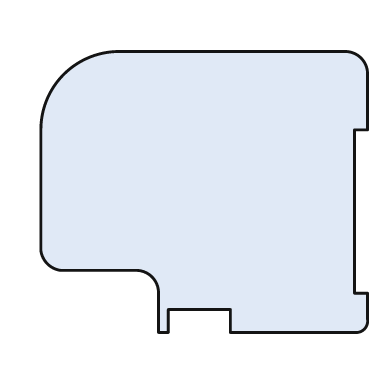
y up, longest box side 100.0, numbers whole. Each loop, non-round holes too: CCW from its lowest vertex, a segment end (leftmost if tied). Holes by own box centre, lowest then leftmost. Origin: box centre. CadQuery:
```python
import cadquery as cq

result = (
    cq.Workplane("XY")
    .moveTo(-14.0, -43.0)
    .lineTo(-11.0, -43.0)
    .lineTo(-11.0, -36.0)
    .lineTo(8.0, -36.0)
    .lineTo(8.0, -43.0)
    .lineTo(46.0, -43.0)
    .threePointArc((49.0, -42.0), (50.0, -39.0))
    .lineTo(50.0, -31.0)
    .lineTo(46.0, -31.0)
    .lineTo(46.0, 19.0)
    .lineTo(50.0, 19.0)
    .lineTo(50.0, 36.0)
    .threePointArc((48.0, 41.0), (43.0, 43.0))
    .lineTo(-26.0, 43.0)
    .threePointArc((-43.0, 36.0), (-50.0, 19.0))
    .lineTo(-50.0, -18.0)
    .threePointArc((-48.0, -22.0), (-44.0, -24.0))
    .lineTo(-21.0, -24.0)
    .threePointArc((-16.0, -26.0), (-14.0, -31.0))
    .close()
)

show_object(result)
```